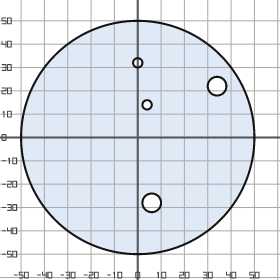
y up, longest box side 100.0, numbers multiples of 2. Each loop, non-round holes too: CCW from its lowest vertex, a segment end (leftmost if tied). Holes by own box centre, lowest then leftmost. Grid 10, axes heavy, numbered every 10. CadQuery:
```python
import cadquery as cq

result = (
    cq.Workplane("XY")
    .moveTo(0.0, 0.0)
    .circle(50.0)
    .moveTo(6.0, -28.0)
    .circle(4.0)
    .moveTo(4.0, 14.0)
    .circle(2.0)
    .moveTo(34.0, 22.0)
    .circle(4.0)
    .moveTo(0.0, 32.0)
    .circle(2.0)
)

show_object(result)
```